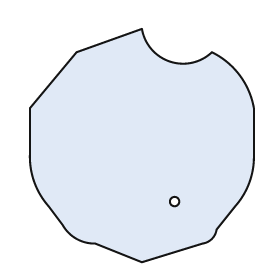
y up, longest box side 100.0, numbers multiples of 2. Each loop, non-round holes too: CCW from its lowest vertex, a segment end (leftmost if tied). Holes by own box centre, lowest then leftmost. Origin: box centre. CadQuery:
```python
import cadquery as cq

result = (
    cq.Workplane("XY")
    .moveTo(0.0, -50.0)
    .lineTo(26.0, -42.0)
    .threePointArc((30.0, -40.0), (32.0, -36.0))
    .lineTo(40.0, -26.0)
    .threePointArc((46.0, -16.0), (48.0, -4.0))
    .lineTo(48.0, 16.0)
    .threePointArc((42.0, 30.0), (30.0, 40.0))
    .threePointArc((12.0, 36.0), (0.0, 50.0))
    .lineTo(-28.0, 40.0)
    .lineTo(-48.0, 16.0)
    .lineTo(-48.0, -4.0)
    .threePointArc((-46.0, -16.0), (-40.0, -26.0))
    .lineTo(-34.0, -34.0)
    .threePointArc((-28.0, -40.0), (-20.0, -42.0))
    .close()
    .moveTo(14.0, -24.0)
    .circle(2.0)
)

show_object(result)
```